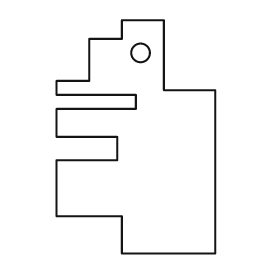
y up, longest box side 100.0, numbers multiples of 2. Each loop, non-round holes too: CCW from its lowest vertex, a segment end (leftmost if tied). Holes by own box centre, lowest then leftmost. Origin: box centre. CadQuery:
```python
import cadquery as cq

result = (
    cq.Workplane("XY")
    .moveTo(-6.0, -50.0)
    .lineTo(34.0, -50.0)
    .lineTo(34.0, 20.0)
    .lineTo(12.0, 20.0)
    .lineTo(12.0, 50.0)
    .lineTo(-6.0, 50.0)
    .lineTo(-6.0, 42.0)
    .lineTo(-20.0, 42.0)
    .lineTo(-20.0, 24.0)
    .lineTo(-34.0, 24.0)
    .lineTo(-34.0, 18.0)
    .lineTo(0.0, 18.0)
    .lineTo(0.0, 12.0)
    .lineTo(-34.0, 12.0)
    .lineTo(-34.0, 0.0)
    .lineTo(-8.0, 0.0)
    .lineTo(-8.0, -10.0)
    .lineTo(-34.0, -10.0)
    .lineTo(-34.0, -34.0)
    .lineTo(-6.0, -34.0)
    .close()
    .moveTo(2.0, 36.0)
    .circle(4.0)
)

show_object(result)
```